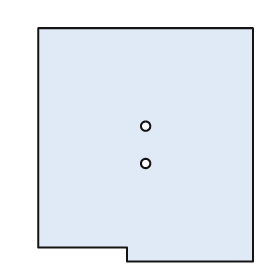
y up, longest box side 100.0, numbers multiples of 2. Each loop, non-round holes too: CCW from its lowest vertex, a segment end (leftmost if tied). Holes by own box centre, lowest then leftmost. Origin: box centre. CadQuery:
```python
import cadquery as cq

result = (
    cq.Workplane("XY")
    .moveTo(-8.0, -50.0)
    .lineTo(46.0, -50.0)
    .lineTo(46.0, 50.0)
    .lineTo(-46.0, 50.0)
    .lineTo(-46.0, -44.0)
    .lineTo(-8.0, -44.0)
    .close()
    .moveTo(0.0, -8.0)
    .circle(2.0)
    .moveTo(0.0, 8.0)
    .circle(2.0)
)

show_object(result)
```